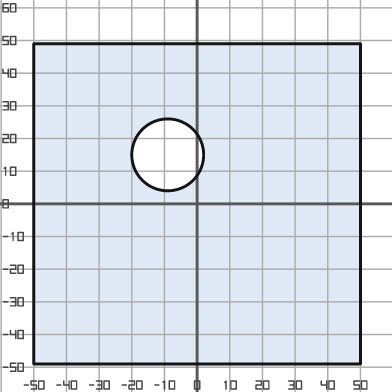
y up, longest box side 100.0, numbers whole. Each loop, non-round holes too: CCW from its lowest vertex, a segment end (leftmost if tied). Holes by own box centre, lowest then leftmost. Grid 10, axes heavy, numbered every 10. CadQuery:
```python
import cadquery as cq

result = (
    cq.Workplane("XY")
    .moveTo(-50.0, -49.0)
    .lineTo(50.0, -49.0)
    .lineTo(50.0, 49.0)
    .lineTo(-50.0, 49.0)
    .close()
    .moveTo(-9.0, 15.0)
    .circle(11.0)
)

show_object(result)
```